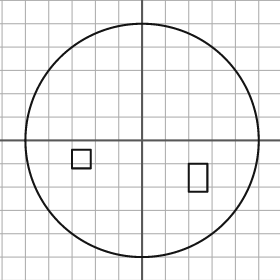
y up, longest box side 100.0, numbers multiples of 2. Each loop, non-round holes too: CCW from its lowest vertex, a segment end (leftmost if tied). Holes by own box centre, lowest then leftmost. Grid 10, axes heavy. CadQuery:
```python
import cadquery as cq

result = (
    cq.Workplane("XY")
    .moveTo(0.0, 0.0)
    .circle(50.0)
    .moveTo(20.0, -22.0)
    .lineTo(28.0, -22.0)
    .lineTo(28.0, -10.0)
    .lineTo(20.0, -10.0)
    .close()
    .moveTo(-30.0, -12.0)
    .lineTo(-22.0, -12.0)
    .lineTo(-22.0, -4.0)
    .lineTo(-30.0, -4.0)
    .close()
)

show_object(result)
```